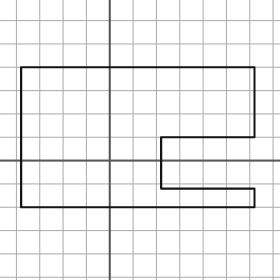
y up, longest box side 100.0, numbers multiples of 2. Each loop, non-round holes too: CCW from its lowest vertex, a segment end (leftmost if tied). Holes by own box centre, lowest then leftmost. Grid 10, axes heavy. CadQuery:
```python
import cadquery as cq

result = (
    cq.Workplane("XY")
    .moveTo(-38.0, -20.0)
    .lineTo(62.0, -20.0)
    .lineTo(62.0, -12.0)
    .lineTo(22.0, -12.0)
    .lineTo(22.0, 10.0)
    .lineTo(62.0, 10.0)
    .lineTo(62.0, 40.0)
    .lineTo(-38.0, 40.0)
    .close()
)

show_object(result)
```